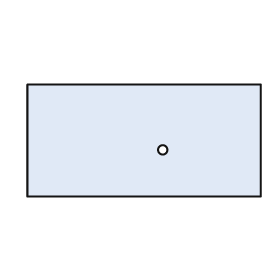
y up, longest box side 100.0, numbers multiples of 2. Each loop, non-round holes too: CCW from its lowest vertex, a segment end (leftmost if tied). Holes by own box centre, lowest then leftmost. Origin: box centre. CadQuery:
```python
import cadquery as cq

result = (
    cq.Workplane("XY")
    .moveTo(-50.0, -24.0)
    .lineTo(50.0, -24.0)
    .lineTo(50.0, 24.0)
    .lineTo(-50.0, 24.0)
    .close()
    .moveTo(8.0, -4.0)
    .circle(2.0)
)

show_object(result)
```